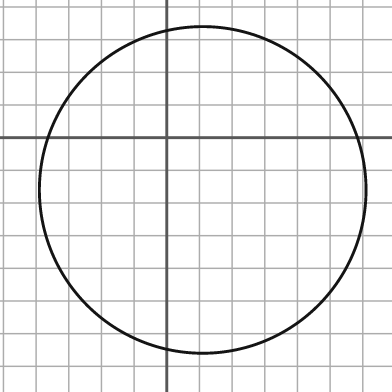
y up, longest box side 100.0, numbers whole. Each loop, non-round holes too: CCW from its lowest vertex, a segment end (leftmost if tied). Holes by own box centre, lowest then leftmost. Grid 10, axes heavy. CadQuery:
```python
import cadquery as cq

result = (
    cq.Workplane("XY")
    .moveTo(11.0, -16.0)
    .circle(50.0)
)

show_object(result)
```